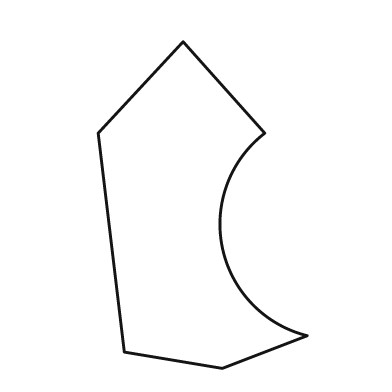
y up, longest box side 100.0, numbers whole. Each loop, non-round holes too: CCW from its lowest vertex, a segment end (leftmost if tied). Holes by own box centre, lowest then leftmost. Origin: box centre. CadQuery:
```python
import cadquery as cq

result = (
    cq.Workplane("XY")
    .moveTo(6.0, -50.0)
    .lineTo(32.0, -40.0)
    .threePointArc((6.0, -13.0), (19.0, 22.0))
    .lineTo(-6.0, 50.0)
    .lineTo(-32.0, 22.0)
    .lineTo(-24.0, -45.0)
    .close()
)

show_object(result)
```